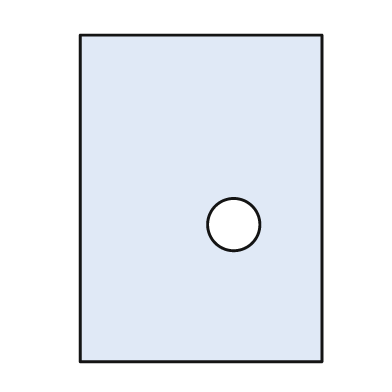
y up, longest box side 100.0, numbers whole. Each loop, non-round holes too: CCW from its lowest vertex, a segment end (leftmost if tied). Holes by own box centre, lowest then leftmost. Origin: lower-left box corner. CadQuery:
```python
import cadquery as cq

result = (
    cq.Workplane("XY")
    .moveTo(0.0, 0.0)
    .lineTo(74.0, 0.0)
    .lineTo(74.0, 100.0)
    .lineTo(0.0, 100.0)
    .close()
    .moveTo(47.0, 42.0)
    .circle(8.0)
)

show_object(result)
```